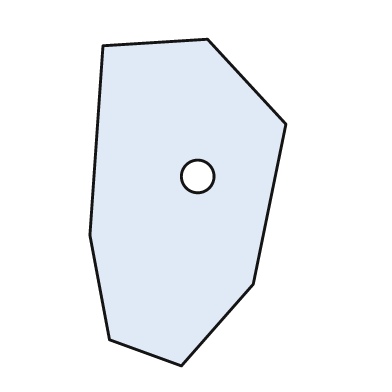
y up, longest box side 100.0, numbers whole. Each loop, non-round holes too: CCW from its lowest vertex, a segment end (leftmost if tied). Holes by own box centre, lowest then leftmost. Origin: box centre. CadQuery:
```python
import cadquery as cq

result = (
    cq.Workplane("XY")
    .moveTo(-2.0, -50.0)
    .lineTo(20.0, -25.0)
    .lineTo(30.0, 24.0)
    .lineTo(6.0, 50.0)
    .lineTo(-26.0, 48.0)
    .lineTo(-30.0, -10.0)
    .lineTo(-24.0, -42.0)
    .close()
    .moveTo(3.0, 8.0)
    .circle(5.0)
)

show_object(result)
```